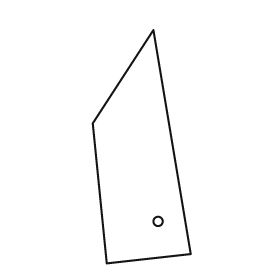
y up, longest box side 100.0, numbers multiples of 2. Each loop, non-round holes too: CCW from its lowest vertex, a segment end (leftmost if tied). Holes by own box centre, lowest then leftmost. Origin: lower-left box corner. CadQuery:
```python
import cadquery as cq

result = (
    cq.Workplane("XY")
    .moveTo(6.0, 0.0)
    .lineTo(42.0, 4.0)
    .lineTo(26.0, 100.0)
    .lineTo(0.0, 60.0)
    .close()
    .moveTo(28.0, 18.0)
    .circle(2.0)
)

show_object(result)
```